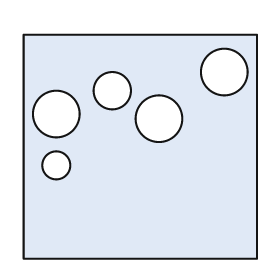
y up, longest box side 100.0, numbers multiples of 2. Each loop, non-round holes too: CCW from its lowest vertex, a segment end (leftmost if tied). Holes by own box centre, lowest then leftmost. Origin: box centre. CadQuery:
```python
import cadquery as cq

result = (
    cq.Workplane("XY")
    .moveTo(-50.0, -48.0)
    .lineTo(50.0, -48.0)
    .lineTo(50.0, 48.0)
    .lineTo(-50.0, 48.0)
    .close()
    .moveTo(-36.0, -8.0)
    .circle(6.0)
    .moveTo(8.0, 12.0)
    .circle(10.0)
    .moveTo(-36.0, 14.0)
    .circle(10.0)
    .moveTo(-12.0, 24.0)
    .circle(8.0)
    .moveTo(36.0, 32.0)
    .circle(10.0)
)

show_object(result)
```